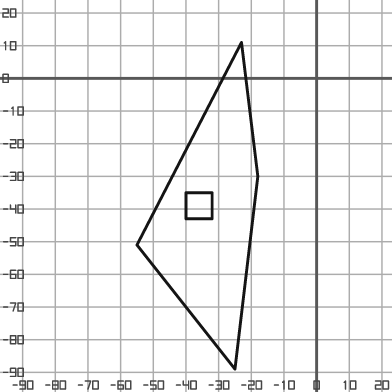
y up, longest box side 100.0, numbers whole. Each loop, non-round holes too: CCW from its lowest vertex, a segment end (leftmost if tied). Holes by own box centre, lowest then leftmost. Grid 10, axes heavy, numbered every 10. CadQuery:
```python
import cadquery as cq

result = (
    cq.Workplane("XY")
    .moveTo(-25.0, -89.0)
    .lineTo(-18.0, -30.0)
    .lineTo(-23.0, 11.0)
    .lineTo(-55.0, -51.0)
    .close()
    .moveTo(-40.0, -43.0)
    .lineTo(-32.0, -43.0)
    .lineTo(-32.0, -35.0)
    .lineTo(-40.0, -35.0)
    .close()
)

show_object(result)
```